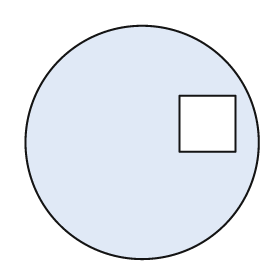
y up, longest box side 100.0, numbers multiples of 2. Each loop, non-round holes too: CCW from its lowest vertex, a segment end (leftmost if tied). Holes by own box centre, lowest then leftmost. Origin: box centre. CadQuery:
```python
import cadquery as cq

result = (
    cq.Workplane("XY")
    .moveTo(0.0, 0.0)
    .circle(50.0)
    .moveTo(16.0, -4.0)
    .lineTo(40.0, -4.0)
    .lineTo(40.0, 20.0)
    .lineTo(16.0, 20.0)
    .close()
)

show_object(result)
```